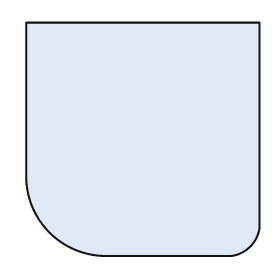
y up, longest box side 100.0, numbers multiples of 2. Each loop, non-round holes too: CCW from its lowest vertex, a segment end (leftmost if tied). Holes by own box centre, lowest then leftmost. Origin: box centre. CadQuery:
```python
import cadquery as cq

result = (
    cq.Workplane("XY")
    .moveTo(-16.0, -50.0)
    .lineTo(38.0, -50.0)
    .threePointArc((46.0, -46.0), (50.0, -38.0))
    .lineTo(50.0, 50.0)
    .lineTo(-50.0, 50.0)
    .lineTo(-50.0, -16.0)
    .threePointArc((-40.0, -40.0), (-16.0, -50.0))
    .close()
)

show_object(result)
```